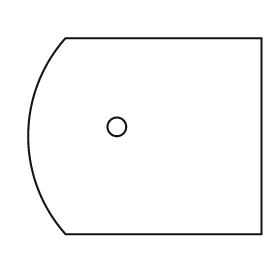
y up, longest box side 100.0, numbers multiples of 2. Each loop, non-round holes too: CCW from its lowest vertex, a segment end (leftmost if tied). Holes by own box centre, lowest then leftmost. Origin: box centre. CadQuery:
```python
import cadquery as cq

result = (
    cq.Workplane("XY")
    .moveTo(-34.0, -42.0)
    .lineTo(50.0, -42.0)
    .lineTo(50.0, 42.0)
    .lineTo(-34.0, 42.0)
    .threePointArc((-50.0, 0.0), (-34.0, -42.0))
    .close()
    .moveTo(-12.0, 4.0)
    .circle(4.0)
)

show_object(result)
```